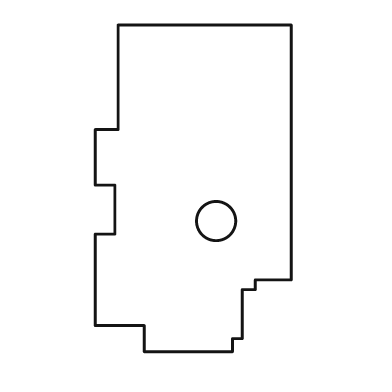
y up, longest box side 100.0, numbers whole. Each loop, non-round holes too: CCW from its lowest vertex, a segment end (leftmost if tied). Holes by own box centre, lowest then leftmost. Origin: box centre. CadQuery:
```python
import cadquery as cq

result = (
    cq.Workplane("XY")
    .moveTo(-15.0, -50.0)
    .lineTo(12.0, -50.0)
    .lineTo(12.0, -46.0)
    .lineTo(15.0, -46.0)
    .lineTo(15.0, -31.0)
    .lineTo(19.0, -31.0)
    .lineTo(19.0, -28.0)
    .lineTo(30.0, -28.0)
    .lineTo(30.0, 50.0)
    .lineTo(-23.0, 50.0)
    .lineTo(-23.0, 18.0)
    .lineTo(-30.0, 18.0)
    .lineTo(-30.0, 1.0)
    .lineTo(-24.0, 1.0)
    .lineTo(-24.0, -14.0)
    .lineTo(-30.0, -14.0)
    .lineTo(-30.0, -42.0)
    .lineTo(-15.0, -42.0)
    .close()
    .moveTo(7.0, -10.0)
    .circle(6.0)
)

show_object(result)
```